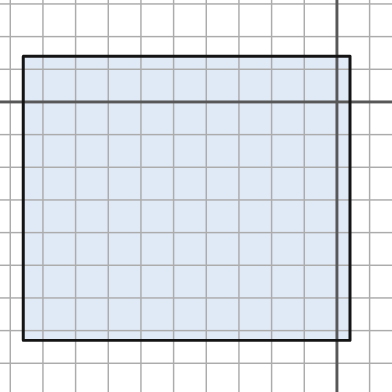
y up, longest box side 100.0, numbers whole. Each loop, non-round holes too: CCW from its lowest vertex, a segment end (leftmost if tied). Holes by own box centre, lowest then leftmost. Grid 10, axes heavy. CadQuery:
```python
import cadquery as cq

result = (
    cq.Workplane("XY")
    .moveTo(-96.0, -73.0)
    .lineTo(4.0, -73.0)
    .lineTo(4.0, 14.0)
    .lineTo(-96.0, 14.0)
    .close()
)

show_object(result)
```